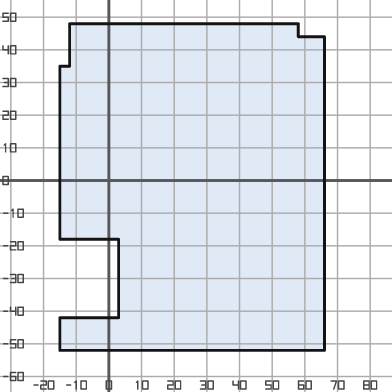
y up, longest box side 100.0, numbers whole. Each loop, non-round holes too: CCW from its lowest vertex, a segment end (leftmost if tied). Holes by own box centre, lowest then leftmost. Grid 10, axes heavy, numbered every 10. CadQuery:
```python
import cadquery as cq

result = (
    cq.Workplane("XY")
    .moveTo(-15.0, -52.0)
    .lineTo(66.0, -52.0)
    .lineTo(66.0, 44.0)
    .lineTo(58.0, 44.0)
    .lineTo(58.0, 48.0)
    .lineTo(-12.0, 48.0)
    .lineTo(-12.0, 35.0)
    .lineTo(-15.0, 35.0)
    .lineTo(-15.0, -18.0)
    .lineTo(3.0, -18.0)
    .lineTo(3.0, -42.0)
    .lineTo(-15.0, -42.0)
    .close()
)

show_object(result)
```